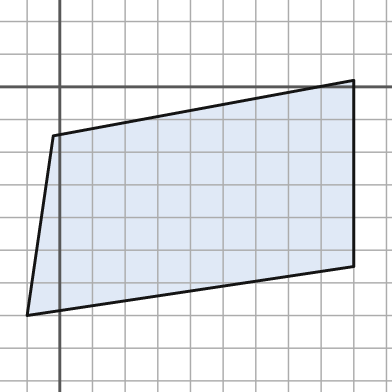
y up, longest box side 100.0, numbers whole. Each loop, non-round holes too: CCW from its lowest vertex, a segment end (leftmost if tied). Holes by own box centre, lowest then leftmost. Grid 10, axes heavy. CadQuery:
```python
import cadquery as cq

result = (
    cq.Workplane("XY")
    .moveTo(-10.0, -70.0)
    .lineTo(90.0, -55.0)
    .lineTo(90.0, 2.0)
    .lineTo(-2.0, -15.0)
    .close()
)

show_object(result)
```